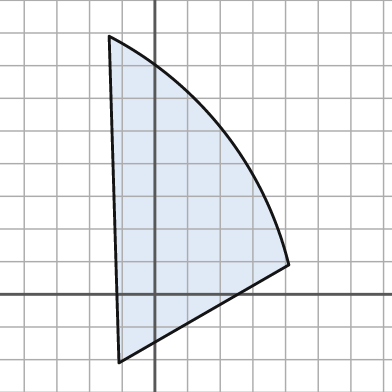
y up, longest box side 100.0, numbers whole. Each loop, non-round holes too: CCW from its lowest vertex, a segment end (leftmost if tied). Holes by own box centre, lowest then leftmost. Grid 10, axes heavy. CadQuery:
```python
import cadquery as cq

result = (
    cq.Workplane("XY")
    .moveTo(-11.0, -21.0)
    .lineTo(41.0, 9.0)
    .threePointArc((21.0, 50.0), (-14.0, 79.0))
    .close()
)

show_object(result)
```